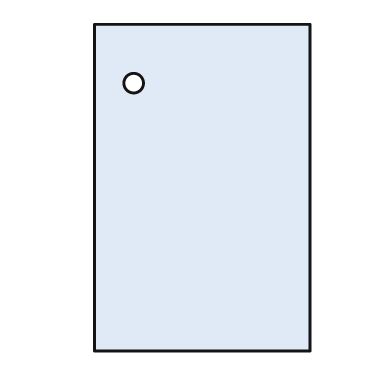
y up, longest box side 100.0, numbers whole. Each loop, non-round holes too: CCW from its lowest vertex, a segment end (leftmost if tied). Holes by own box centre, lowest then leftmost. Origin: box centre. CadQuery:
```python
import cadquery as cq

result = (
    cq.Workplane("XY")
    .moveTo(-33.0, -50.0)
    .lineTo(33.0, -50.0)
    .lineTo(33.0, 50.0)
    .lineTo(-33.0, 50.0)
    .close()
    .moveTo(-21.0, 32.0)
    .circle(3.0)
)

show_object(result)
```